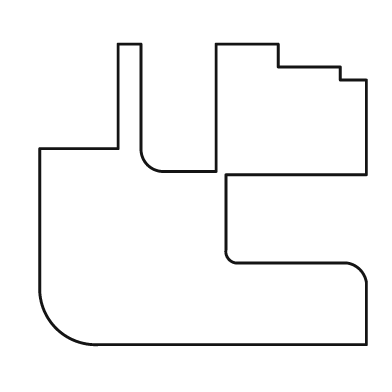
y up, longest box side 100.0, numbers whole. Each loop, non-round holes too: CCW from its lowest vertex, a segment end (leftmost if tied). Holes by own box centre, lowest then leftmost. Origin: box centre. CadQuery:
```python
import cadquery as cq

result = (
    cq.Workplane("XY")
    .moveTo(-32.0, -46.0)
    .lineTo(50.0, -46.0)
    .lineTo(50.0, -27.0)
    .threePointArc((48.0, -23.0), (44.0, -21.0))
    .lineTo(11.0, -21.0)
    .threePointArc((8.0, -20.0), (7.0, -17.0))
    .lineTo(7.0, 6.0)
    .lineTo(50.0, 6.0)
    .lineTo(50.0, 35.0)
    .lineTo(42.0, 35.0)
    .lineTo(42.0, 39.0)
    .lineTo(23.0, 39.0)
    .lineTo(23.0, 46.0)
    .lineTo(4.0, 46.0)
    .lineTo(4.0, 7.0)
    .lineTo(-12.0, 7.0)
    .threePointArc((-17.0, 9.0), (-19.0, 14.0))
    .lineTo(-19.0, 46.0)
    .lineTo(-26.0, 46.0)
    .lineTo(-26.0, 14.0)
    .lineTo(-50.0, 14.0)
    .lineTo(-50.0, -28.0)
    .threePointArc((-45.0, -41.0), (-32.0, -46.0))
    .close()
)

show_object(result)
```